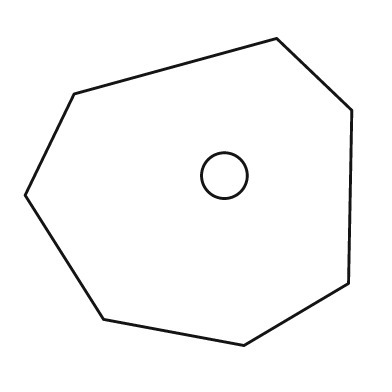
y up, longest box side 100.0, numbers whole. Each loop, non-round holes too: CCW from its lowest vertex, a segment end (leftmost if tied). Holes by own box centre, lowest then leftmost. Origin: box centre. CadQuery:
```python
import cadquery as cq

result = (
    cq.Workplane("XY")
    .moveTo(17.0, -47.0)
    .lineTo(49.0, -28.0)
    .lineTo(50.0, 25.0)
    .lineTo(27.0, 47.0)
    .lineTo(-35.0, 30.0)
    .lineTo(-50.0, -1.0)
    .lineTo(-26.0, -39.0)
    .close()
    .moveTo(11.0, 5.0)
    .circle(7.0)
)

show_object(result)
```